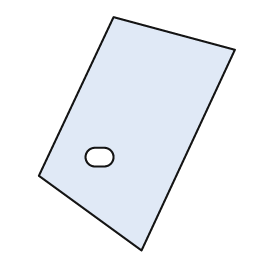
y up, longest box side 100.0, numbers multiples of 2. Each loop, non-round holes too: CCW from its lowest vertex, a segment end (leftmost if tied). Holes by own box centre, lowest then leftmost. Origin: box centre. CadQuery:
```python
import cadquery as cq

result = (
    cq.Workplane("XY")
    .moveTo(2.0, -50.0)
    .lineTo(42.0, 36.0)
    .lineTo(-10.0, 50.0)
    .lineTo(-42.0, -18.0)
    .close()
    .moveTo(-18.0, -14.0)
    .lineTo(-14.0, -14.0)
    .threePointArc((-10.0, -10.0), (-14.0, -6.0))
    .lineTo(-18.0, -6.0)
    .threePointArc((-22.0, -10.0), (-18.0, -14.0))
    .close()
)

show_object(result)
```